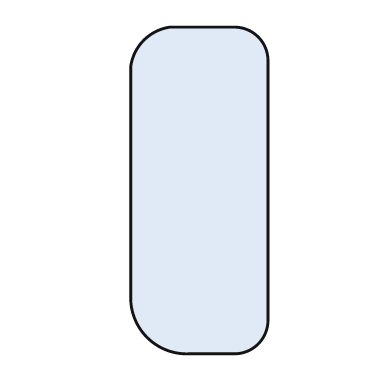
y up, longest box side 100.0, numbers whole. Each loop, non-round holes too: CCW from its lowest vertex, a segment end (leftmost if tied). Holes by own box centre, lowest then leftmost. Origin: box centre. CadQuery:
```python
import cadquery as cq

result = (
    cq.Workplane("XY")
    .moveTo(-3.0, -50.0)
    .lineTo(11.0, -50.0)
    .threePointArc((18.0, -47.0), (21.0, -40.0))
    .lineTo(21.0, 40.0)
    .threePointArc((18.0, 47.0), (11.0, 50.0))
    .lineTo(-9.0, 50.0)
    .threePointArc((-17.0, 46.0), (-21.0, 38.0))
    .lineTo(-21.0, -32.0)
    .threePointArc((-16.0, -45.0), (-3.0, -50.0))
    .close()
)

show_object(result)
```